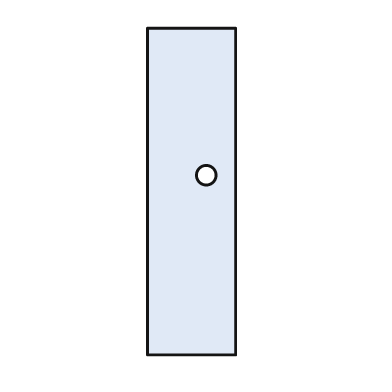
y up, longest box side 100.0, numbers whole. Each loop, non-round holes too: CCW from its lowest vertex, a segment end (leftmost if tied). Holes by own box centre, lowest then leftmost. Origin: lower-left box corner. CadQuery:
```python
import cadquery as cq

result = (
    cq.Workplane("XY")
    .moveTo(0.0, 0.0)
    .lineTo(27.0, 0.0)
    .lineTo(27.0, 100.0)
    .lineTo(0.0, 100.0)
    .close()
    .moveTo(18.0, 55.0)
    .circle(3.0)
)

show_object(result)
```